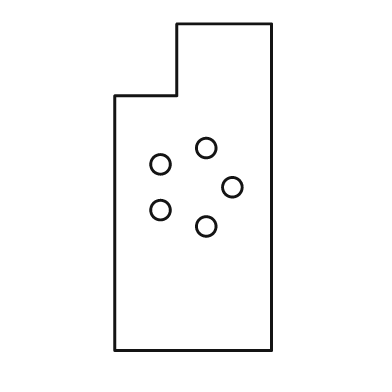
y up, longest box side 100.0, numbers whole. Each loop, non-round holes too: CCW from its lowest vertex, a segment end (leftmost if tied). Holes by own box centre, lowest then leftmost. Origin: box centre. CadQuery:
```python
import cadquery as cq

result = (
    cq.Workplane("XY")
    .moveTo(-24.0, -50.0)
    .lineTo(24.0, -50.0)
    .lineTo(24.0, 50.0)
    .lineTo(-5.0, 50.0)
    .lineTo(-5.0, 28.0)
    .lineTo(-24.0, 28.0)
    .close()
    .moveTo(4.0, -12.0)
    .circle(3.0)
    .moveTo(-10.0, -7.0)
    .circle(3.0)
    .moveTo(12.0, 0.0)
    .circle(3.0)
    .moveTo(-10.0, 7.0)
    .circle(3.0)
    .moveTo(4.0, 12.0)
    .circle(3.0)
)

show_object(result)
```